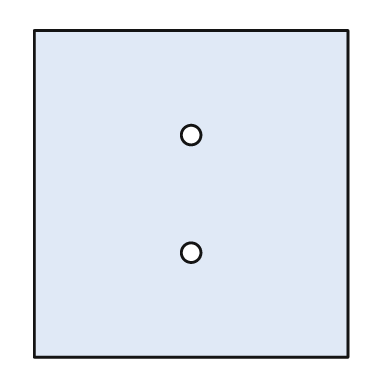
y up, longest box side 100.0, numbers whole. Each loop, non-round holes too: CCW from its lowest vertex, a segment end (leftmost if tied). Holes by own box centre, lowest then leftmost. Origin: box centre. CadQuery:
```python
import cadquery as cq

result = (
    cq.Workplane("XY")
    .moveTo(-48.0, -50.0)
    .lineTo(48.0, -50.0)
    .lineTo(48.0, 50.0)
    .lineTo(-48.0, 50.0)
    .close()
    .moveTo(0.0, -18.0)
    .circle(3.0)
    .moveTo(0.0, 18.0)
    .circle(3.0)
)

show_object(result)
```